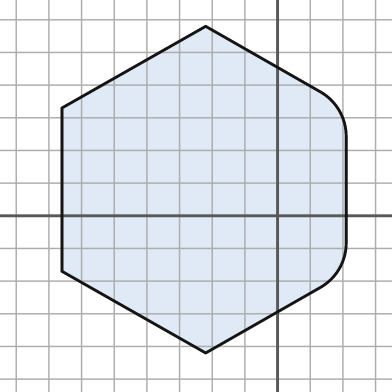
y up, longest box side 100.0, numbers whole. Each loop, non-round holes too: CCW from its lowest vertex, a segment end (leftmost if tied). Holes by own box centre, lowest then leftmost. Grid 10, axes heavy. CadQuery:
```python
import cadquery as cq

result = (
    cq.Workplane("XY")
    .moveTo(-22.0, -42.0)
    .lineTo(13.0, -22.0)
    .threePointArc((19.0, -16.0), (21.0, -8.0))
    .lineTo(21.0, 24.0)
    .threePointArc((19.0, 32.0), (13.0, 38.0))
    .lineTo(-22.0, 58.0)
    .lineTo(-66.0, 33.0)
    .lineTo(-66.0, -17.0)
    .close()
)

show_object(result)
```